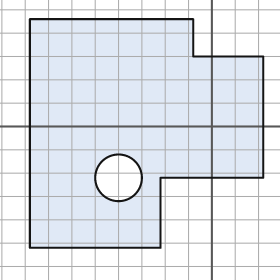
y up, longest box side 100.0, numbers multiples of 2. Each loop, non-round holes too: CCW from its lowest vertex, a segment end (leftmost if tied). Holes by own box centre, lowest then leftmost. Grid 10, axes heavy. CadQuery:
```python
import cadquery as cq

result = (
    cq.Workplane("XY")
    .moveTo(-78.0, -52.0)
    .lineTo(-22.0, -52.0)
    .lineTo(-22.0, -22.0)
    .lineTo(22.0, -22.0)
    .lineTo(22.0, 30.0)
    .lineTo(-8.0, 30.0)
    .lineTo(-8.0, 46.0)
    .lineTo(-78.0, 46.0)
    .close()
    .moveTo(-40.0, -22.0)
    .circle(10.0)
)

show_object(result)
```